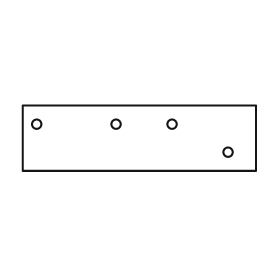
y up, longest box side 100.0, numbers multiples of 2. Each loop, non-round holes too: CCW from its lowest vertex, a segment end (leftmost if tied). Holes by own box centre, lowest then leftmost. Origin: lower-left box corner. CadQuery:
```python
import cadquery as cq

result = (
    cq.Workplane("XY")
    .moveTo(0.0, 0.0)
    .lineTo(100.0, 0.0)
    .lineTo(100.0, 28.0)
    .lineTo(0.0, 28.0)
    .close()
    .moveTo(88.0, 8.0)
    .circle(2.0)
    .moveTo(6.0, 20.0)
    .circle(2.0)
    .moveTo(40.0, 20.0)
    .circle(2.0)
    .moveTo(64.0, 20.0)
    .circle(2.0)
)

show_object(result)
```